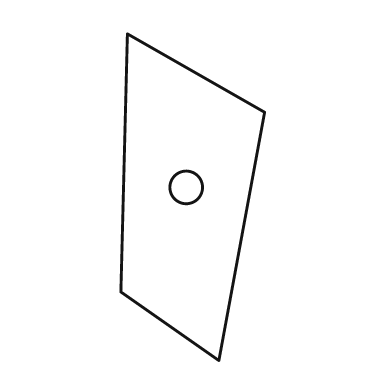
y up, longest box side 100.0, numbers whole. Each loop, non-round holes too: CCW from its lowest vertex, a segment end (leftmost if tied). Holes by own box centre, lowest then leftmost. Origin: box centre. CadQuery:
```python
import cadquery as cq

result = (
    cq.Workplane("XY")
    .moveTo(8.0, -50.0)
    .lineTo(22.0, 26.0)
    .lineTo(-20.0, 50.0)
    .lineTo(-22.0, -29.0)
    .close()
    .moveTo(-2.0, 3.0)
    .circle(5.0)
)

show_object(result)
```